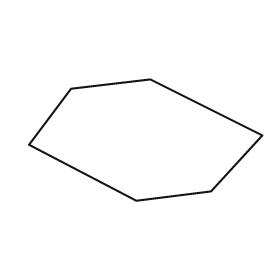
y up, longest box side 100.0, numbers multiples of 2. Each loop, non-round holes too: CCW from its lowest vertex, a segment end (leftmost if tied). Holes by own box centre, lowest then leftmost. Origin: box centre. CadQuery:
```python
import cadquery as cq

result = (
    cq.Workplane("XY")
    .moveTo(-4.0, -26.0)
    .lineTo(28.0, -22.0)
    .lineTo(50.0, 2.0)
    .lineTo(2.0, 26.0)
    .lineTo(-32.0, 22.0)
    .lineTo(-50.0, -2.0)
    .close()
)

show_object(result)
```